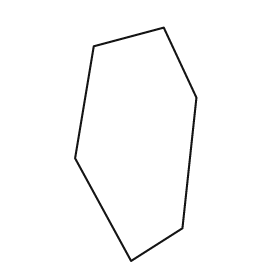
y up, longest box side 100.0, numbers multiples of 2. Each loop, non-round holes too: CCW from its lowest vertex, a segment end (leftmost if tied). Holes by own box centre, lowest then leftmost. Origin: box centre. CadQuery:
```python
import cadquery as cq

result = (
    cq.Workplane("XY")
    .moveTo(-2.0, -50.0)
    .lineTo(20.0, -36.0)
    .lineTo(26.0, 20.0)
    .lineTo(12.0, 50.0)
    .lineTo(-18.0, 42.0)
    .lineTo(-26.0, -6.0)
    .close()
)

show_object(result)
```